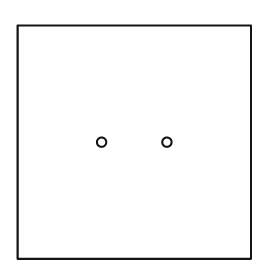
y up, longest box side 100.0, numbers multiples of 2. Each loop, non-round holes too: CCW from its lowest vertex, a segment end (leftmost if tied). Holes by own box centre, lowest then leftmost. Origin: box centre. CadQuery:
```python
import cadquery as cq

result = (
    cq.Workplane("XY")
    .moveTo(-50.0, -50.0)
    .lineTo(50.0, -50.0)
    .lineTo(50.0, 50.0)
    .lineTo(-50.0, 50.0)
    .close()
    .moveTo(-14.0, 0.0)
    .circle(2.0)
    .moveTo(14.0, 0.0)
    .circle(2.0)
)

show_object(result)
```